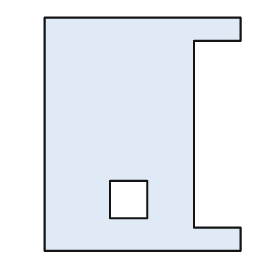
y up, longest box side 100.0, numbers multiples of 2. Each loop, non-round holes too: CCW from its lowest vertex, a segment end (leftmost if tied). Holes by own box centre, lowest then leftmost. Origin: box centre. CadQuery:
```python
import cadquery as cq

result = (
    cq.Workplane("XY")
    .moveTo(-42.0, -50.0)
    .lineTo(42.0, -50.0)
    .lineTo(42.0, -40.0)
    .lineTo(22.0, -40.0)
    .lineTo(22.0, 40.0)
    .lineTo(42.0, 40.0)
    .lineTo(42.0, 50.0)
    .lineTo(-42.0, 50.0)
    .close()
    .moveTo(-14.0, -36.0)
    .lineTo(2.0, -36.0)
    .lineTo(2.0, -20.0)
    .lineTo(-14.0, -20.0)
    .close()
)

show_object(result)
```